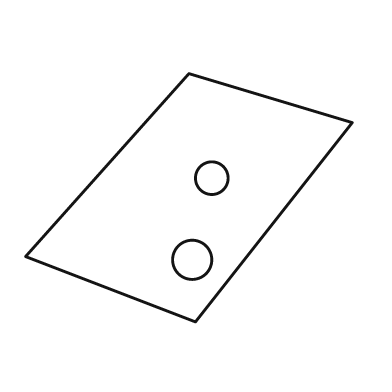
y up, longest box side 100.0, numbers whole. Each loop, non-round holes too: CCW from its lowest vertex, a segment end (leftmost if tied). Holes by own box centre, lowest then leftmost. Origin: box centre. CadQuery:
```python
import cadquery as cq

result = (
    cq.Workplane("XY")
    .moveTo(2.0, -38.0)
    .lineTo(50.0, 23.0)
    .lineTo(0.0, 38.0)
    .lineTo(-50.0, -18.0)
    .close()
    .moveTo(1.0, -19.0)
    .circle(6.0)
    .moveTo(7.0, 6.0)
    .circle(5.0)
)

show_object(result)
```